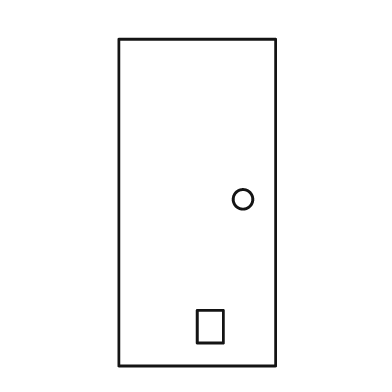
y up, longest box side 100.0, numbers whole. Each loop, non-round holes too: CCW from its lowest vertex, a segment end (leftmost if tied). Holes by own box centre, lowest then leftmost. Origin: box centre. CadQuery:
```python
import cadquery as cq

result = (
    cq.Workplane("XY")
    .moveTo(-24.0, -50.0)
    .lineTo(24.0, -50.0)
    .lineTo(24.0, 50.0)
    .lineTo(-24.0, 50.0)
    .close()
    .moveTo(0.0, -43.0)
    .lineTo(8.0, -43.0)
    .lineTo(8.0, -33.0)
    .lineTo(0.0, -33.0)
    .close()
    .moveTo(14.0, 1.0)
    .circle(3.0)
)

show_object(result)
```